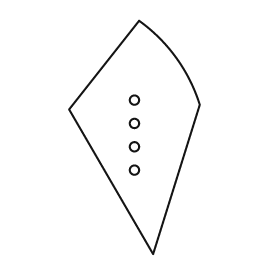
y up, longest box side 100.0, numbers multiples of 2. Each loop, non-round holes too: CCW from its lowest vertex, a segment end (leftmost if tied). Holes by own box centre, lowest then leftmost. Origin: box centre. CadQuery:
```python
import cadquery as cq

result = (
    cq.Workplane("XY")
    .moveTo(8.0, -50.0)
    .lineTo(28.0, 14.0)
    .threePointArc((18.0, 34.0), (2.0, 50.0))
    .lineTo(-28.0, 12.0)
    .close()
    .moveTo(0.0, -14.0)
    .circle(2.0)
    .moveTo(0.0, -4.0)
    .circle(2.0)
    .moveTo(0.0, 6.0)
    .circle(2.0)
    .moveTo(0.0, 16.0)
    .circle(2.0)
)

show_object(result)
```